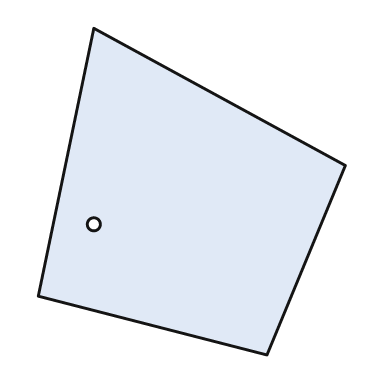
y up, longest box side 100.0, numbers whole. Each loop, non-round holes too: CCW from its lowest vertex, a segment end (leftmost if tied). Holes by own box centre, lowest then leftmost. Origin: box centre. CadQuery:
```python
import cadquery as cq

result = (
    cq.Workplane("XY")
    .moveTo(23.0, -50.0)
    .lineTo(47.0, 8.0)
    .lineTo(-30.0, 50.0)
    .lineTo(-47.0, -32.0)
    .close()
    .moveTo(-30.0, -10.0)
    .circle(2.0)
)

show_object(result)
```